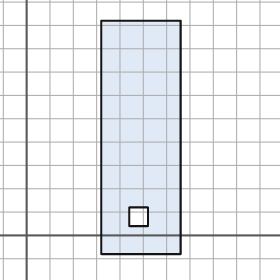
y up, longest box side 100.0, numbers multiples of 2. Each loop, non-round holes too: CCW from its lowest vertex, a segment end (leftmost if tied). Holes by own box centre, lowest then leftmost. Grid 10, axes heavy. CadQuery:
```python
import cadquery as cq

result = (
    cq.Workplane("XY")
    .moveTo(32.0, -8.0)
    .lineTo(66.0, -8.0)
    .lineTo(66.0, 92.0)
    .lineTo(32.0, 92.0)
    .close()
    .moveTo(44.0, 4.0)
    .lineTo(52.0, 4.0)
    .lineTo(52.0, 12.0)
    .lineTo(44.0, 12.0)
    .close()
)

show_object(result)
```